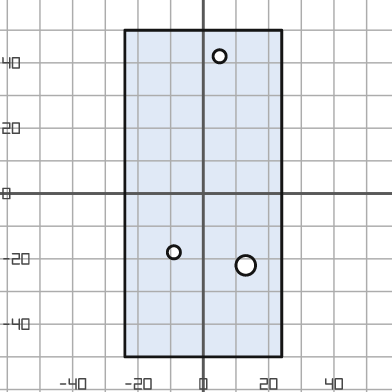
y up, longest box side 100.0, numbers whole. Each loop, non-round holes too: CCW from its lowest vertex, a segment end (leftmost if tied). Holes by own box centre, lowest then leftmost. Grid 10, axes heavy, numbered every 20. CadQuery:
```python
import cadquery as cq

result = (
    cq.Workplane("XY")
    .moveTo(-24.0, -50.0)
    .lineTo(24.0, -50.0)
    .lineTo(24.0, 50.0)
    .lineTo(-24.0, 50.0)
    .close()
    .moveTo(13.0, -22.0)
    .circle(3.0)
    .moveTo(-9.0, -18.0)
    .circle(2.0)
    .moveTo(5.0, 42.0)
    .circle(2.0)
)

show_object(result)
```